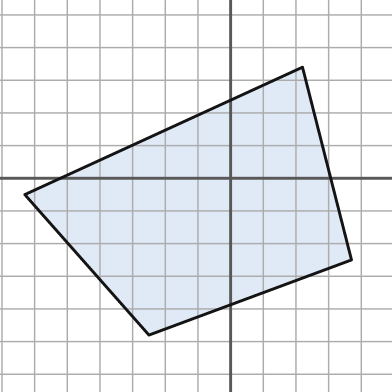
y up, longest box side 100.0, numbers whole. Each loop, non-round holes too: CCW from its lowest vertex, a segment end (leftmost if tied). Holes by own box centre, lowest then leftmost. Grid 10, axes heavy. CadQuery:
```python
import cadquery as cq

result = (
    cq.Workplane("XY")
    .moveTo(-25.0, -48.0)
    .lineTo(37.0, -25.0)
    .lineTo(22.0, 34.0)
    .lineTo(-63.0, -5.0)
    .close()
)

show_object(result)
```